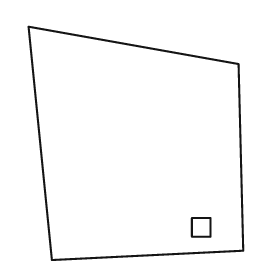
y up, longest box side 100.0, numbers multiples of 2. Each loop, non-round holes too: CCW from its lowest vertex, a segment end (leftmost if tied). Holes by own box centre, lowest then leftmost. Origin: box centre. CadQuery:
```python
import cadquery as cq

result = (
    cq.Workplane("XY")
    .moveTo(-36.0, -50.0)
    .lineTo(46.0, -46.0)
    .lineTo(44.0, 34.0)
    .lineTo(-46.0, 50.0)
    .close()
    .moveTo(24.0, -40.0)
    .lineTo(32.0, -40.0)
    .lineTo(32.0, -32.0)
    .lineTo(24.0, -32.0)
    .close()
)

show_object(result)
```